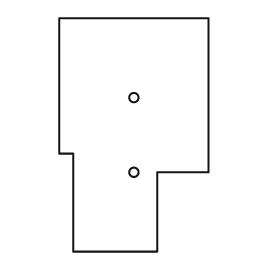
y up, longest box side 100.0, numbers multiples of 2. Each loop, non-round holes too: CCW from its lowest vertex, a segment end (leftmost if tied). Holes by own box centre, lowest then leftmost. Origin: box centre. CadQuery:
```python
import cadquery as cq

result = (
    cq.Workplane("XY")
    .moveTo(-26.0, -50.0)
    .lineTo(10.0, -50.0)
    .lineTo(10.0, -16.0)
    .lineTo(32.0, -16.0)
    .lineTo(32.0, 50.0)
    .lineTo(-32.0, 50.0)
    .lineTo(-32.0, -8.0)
    .lineTo(-26.0, -8.0)
    .close()
    .moveTo(0.0, -16.0)
    .circle(2.0)
    .moveTo(0.0, 16.0)
    .circle(2.0)
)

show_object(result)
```